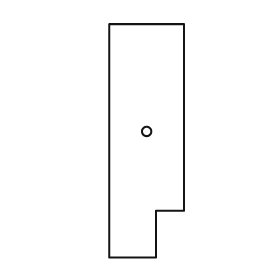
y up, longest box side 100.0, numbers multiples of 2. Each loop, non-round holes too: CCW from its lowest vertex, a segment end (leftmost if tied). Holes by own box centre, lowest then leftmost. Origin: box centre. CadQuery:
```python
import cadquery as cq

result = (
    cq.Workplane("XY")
    .moveTo(-16.0, -50.0)
    .lineTo(4.0, -50.0)
    .lineTo(4.0, -30.0)
    .lineTo(16.0, -30.0)
    .lineTo(16.0, 50.0)
    .lineTo(-16.0, 50.0)
    .close()
    .moveTo(0.0, 4.0)
    .circle(2.0)
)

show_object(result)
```